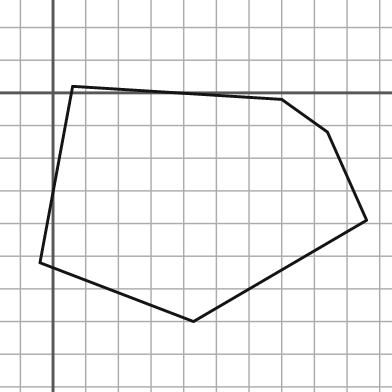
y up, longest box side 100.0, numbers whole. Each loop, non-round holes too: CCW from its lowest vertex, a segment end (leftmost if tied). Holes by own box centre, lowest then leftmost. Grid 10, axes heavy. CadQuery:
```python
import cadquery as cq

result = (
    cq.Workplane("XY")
    .moveTo(43.0, -70.0)
    .lineTo(96.0, -39.0)
    .lineTo(84.0, -12.0)
    .lineTo(70.0, -2.0)
    .lineTo(6.0, 2.0)
    .lineTo(-4.0, -52.0)
    .close()
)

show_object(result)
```